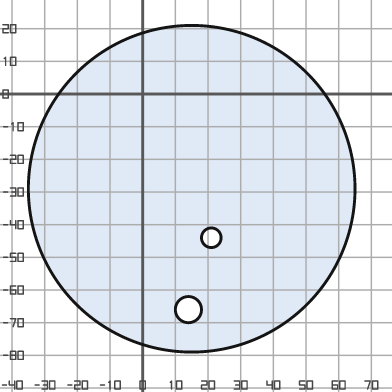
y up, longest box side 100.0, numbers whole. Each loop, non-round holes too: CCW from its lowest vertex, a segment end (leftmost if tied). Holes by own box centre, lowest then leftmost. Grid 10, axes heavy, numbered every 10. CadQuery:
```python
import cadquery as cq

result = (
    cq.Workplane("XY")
    .moveTo(15.0, -29.0)
    .circle(50.0)
    .moveTo(14.0, -66.0)
    .circle(4.0)
    .moveTo(21.0, -44.0)
    .circle(3.0)
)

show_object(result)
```